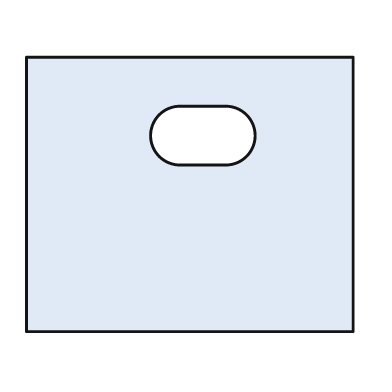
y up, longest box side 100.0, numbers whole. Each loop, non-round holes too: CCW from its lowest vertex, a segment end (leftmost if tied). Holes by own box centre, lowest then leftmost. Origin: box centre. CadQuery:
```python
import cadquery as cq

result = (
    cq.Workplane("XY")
    .moveTo(-50.0, -42.0)
    .lineTo(50.0, -42.0)
    .lineTo(50.0, 42.0)
    .lineTo(-50.0, 42.0)
    .close()
    .moveTo(-3.0, 9.0)
    .lineTo(11.0, 9.0)
    .threePointArc((20.0, 18.0), (11.0, 27.0))
    .lineTo(-3.0, 27.0)
    .threePointArc((-12.0, 18.0), (-3.0, 9.0))
    .close()
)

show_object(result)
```